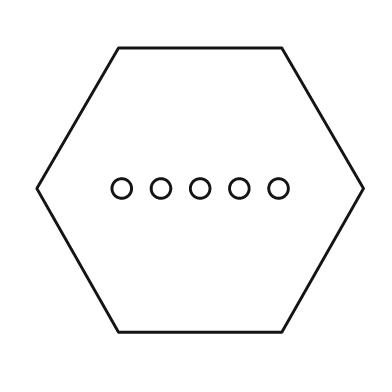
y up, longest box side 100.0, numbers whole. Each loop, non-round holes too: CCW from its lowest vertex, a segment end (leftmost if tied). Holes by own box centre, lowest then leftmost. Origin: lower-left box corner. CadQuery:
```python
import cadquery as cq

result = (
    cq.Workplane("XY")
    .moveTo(25.0, 0.0)
    .lineTo(75.0, 0.0)
    .lineTo(100.0, 44.0)
    .lineTo(75.0, 87.0)
    .lineTo(25.0, 87.0)
    .lineTo(0.0, 44.0)
    .close()
    .moveTo(26.0, 44.0)
    .circle(3.0)
    .moveTo(38.0, 44.0)
    .circle(3.0)
    .moveTo(50.0, 44.0)
    .circle(3.0)
    .moveTo(62.0, 44.0)
    .circle(3.0)
    .moveTo(74.0, 44.0)
    .circle(3.0)
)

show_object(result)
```